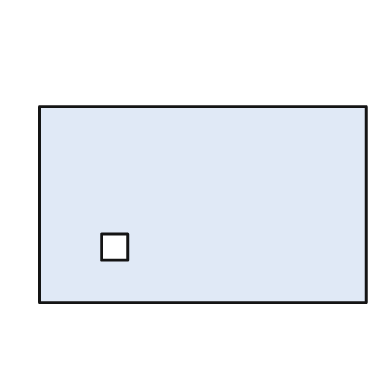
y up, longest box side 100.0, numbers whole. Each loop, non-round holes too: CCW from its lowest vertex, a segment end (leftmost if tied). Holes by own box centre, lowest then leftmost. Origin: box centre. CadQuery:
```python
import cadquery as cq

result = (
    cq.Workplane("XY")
    .moveTo(-50.0, -30.0)
    .lineTo(50.0, -30.0)
    .lineTo(50.0, 30.0)
    .lineTo(-50.0, 30.0)
    .close()
    .moveTo(-31.0, -17.0)
    .lineTo(-23.0, -17.0)
    .lineTo(-23.0, -9.0)
    .lineTo(-31.0, -9.0)
    .close()
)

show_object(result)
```